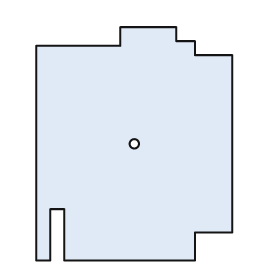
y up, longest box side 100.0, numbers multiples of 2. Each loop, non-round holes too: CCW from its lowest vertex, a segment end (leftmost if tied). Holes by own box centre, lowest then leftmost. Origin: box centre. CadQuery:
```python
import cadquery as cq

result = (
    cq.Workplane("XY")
    .moveTo(-42.0, -50.0)
    .lineTo(-36.0, -50.0)
    .lineTo(-36.0, -28.0)
    .lineTo(-30.0, -28.0)
    .lineTo(-30.0, -50.0)
    .lineTo(26.0, -50.0)
    .lineTo(26.0, -38.0)
    .lineTo(42.0, -38.0)
    .lineTo(42.0, 38.0)
    .lineTo(26.0, 38.0)
    .lineTo(26.0, 44.0)
    .lineTo(18.0, 44.0)
    .lineTo(18.0, 50.0)
    .lineTo(-6.0, 50.0)
    .lineTo(-6.0, 42.0)
    .lineTo(-42.0, 42.0)
    .close()
    .moveTo(0.0, 0.0)
    .circle(2.0)
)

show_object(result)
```